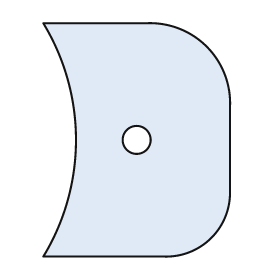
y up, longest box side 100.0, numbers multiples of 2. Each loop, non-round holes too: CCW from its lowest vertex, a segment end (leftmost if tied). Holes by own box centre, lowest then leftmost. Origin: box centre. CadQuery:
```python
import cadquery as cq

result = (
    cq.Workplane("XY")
    .moveTo(-40.0, -50.0)
    .lineTo(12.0, -50.0)
    .threePointArc((32.0, -42.0), (40.0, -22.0))
    .lineTo(40.0, 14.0)
    .threePointArc((30.0, 40.0), (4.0, 50.0))
    .lineTo(-40.0, 50.0)
    .threePointArc((-26.0, 0.0), (-40.0, -50.0))
    .close()
    .moveTo(0.0, 0.0)
    .circle(6.0)
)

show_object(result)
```